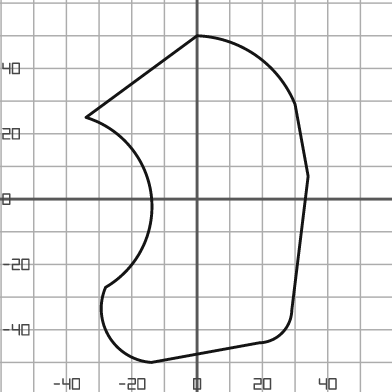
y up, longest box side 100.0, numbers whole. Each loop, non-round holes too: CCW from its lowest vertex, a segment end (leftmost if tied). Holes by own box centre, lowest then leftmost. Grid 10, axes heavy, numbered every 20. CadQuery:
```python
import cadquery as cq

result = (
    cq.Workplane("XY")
    .moveTo(-14.0, -50.0)
    .lineTo(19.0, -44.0)
    .threePointArc((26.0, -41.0), (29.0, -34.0))
    .lineTo(34.0, 7.0)
    .lineTo(30.0, 29.0)
    .threePointArc((18.0, 44.0), (0.0, 50.0))
    .lineTo(-34.0, 25.0)
    .threePointArc((-14.0, 1.0), (-28.0, -27.0))
    .threePointArc((-27.0, -42.0), (-14.0, -50.0))
    .close()
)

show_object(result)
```